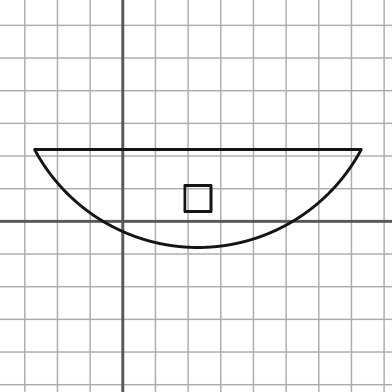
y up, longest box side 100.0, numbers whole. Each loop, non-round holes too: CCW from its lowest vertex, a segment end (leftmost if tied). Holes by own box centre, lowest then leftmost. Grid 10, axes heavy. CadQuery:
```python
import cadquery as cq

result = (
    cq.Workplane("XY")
    .moveTo(-27.0, 22.0)
    .threePointArc((23.0, -8.0), (73.0, 22.0))
    .close()
    .moveTo(19.0, 3.0)
    .lineTo(27.0, 3.0)
    .lineTo(27.0, 11.0)
    .lineTo(19.0, 11.0)
    .close()
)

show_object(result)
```